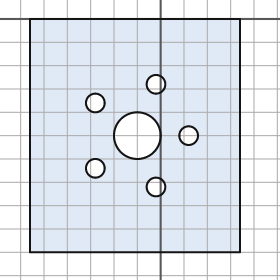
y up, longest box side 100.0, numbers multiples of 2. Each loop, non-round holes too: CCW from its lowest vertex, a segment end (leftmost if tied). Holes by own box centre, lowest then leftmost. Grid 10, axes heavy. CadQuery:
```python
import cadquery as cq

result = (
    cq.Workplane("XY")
    .moveTo(-56.0, -100.0)
    .lineTo(34.0, -100.0)
    .lineTo(34.0, 0.0)
    .lineTo(-56.0, 0.0)
    .close()
    .moveTo(-2.0, -72.0)
    .circle(4.0)
    .moveTo(-28.0, -64.0)
    .circle(4.0)
    .moveTo(-10.0, -50.0)
    .circle(10.0)
    .moveTo(12.0, -50.0)
    .circle(4.0)
    .moveTo(-28.0, -36.0)
    .circle(4.0)
    .moveTo(-2.0, -28.0)
    .circle(4.0)
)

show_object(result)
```